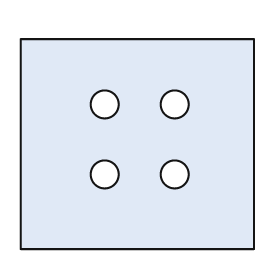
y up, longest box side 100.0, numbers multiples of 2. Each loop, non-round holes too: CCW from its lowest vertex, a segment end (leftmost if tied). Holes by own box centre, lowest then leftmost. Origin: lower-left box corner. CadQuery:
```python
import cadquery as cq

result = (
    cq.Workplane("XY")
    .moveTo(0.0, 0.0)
    .lineTo(100.0, 0.0)
    .lineTo(100.0, 90.0)
    .lineTo(0.0, 90.0)
    .close()
    .moveTo(36.0, 32.0)
    .circle(6.0)
    .moveTo(66.0, 32.0)
    .circle(6.0)
    .moveTo(36.0, 62.0)
    .circle(6.0)
    .moveTo(66.0, 62.0)
    .circle(6.0)
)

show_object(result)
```